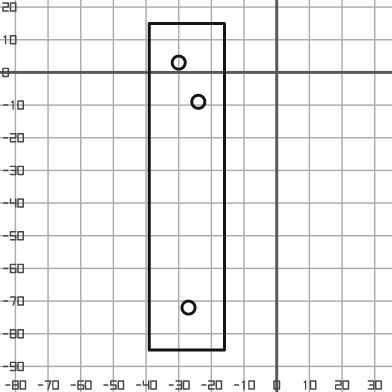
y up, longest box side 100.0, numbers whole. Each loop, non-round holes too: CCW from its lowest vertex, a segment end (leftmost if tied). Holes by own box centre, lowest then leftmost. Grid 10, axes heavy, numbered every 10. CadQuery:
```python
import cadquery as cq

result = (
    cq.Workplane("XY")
    .moveTo(-39.0, -85.0)
    .lineTo(-16.0, -85.0)
    .lineTo(-16.0, 15.0)
    .lineTo(-39.0, 15.0)
    .close()
    .moveTo(-27.0, -72.0)
    .circle(2.0)
    .moveTo(-24.0, -9.0)
    .circle(2.0)
    .moveTo(-30.0, 3.0)
    .circle(2.0)
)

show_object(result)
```